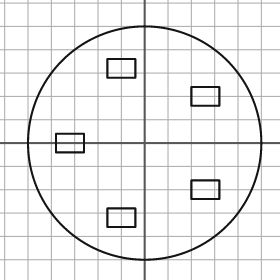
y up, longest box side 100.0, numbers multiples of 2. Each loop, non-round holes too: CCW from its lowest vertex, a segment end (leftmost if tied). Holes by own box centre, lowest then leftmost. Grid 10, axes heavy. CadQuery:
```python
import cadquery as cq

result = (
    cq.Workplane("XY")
    .moveTo(0.0, 0.0)
    .circle(50.0)
    .moveTo(-16.0, -36.0)
    .lineTo(-4.0, -36.0)
    .lineTo(-4.0, -28.0)
    .lineTo(-16.0, -28.0)
    .close()
    .moveTo(20.0, -24.0)
    .lineTo(32.0, -24.0)
    .lineTo(32.0, -16.0)
    .lineTo(20.0, -16.0)
    .close()
    .moveTo(-38.0, -4.0)
    .lineTo(-26.0, -4.0)
    .lineTo(-26.0, 4.0)
    .lineTo(-38.0, 4.0)
    .close()
    .moveTo(20.0, 16.0)
    .lineTo(32.0, 16.0)
    .lineTo(32.0, 24.0)
    .lineTo(20.0, 24.0)
    .close()
    .moveTo(-16.0, 28.0)
    .lineTo(-4.0, 28.0)
    .lineTo(-4.0, 36.0)
    .lineTo(-16.0, 36.0)
    .close()
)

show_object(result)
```